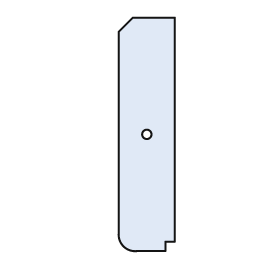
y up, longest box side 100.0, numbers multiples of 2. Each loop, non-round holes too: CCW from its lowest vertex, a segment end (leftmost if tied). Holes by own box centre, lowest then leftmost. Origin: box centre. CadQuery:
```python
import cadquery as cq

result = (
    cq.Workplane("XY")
    .moveTo(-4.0, -50.0)
    .lineTo(8.0, -50.0)
    .lineTo(8.0, -46.0)
    .lineTo(12.0, -46.0)
    .lineTo(12.0, 50.0)
    .lineTo(-6.0, 50.0)
    .lineTo(-12.0, 44.0)
    .lineTo(-12.0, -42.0)
    .threePointArc((-10.0, -48.0), (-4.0, -50.0))
    .close()
    .moveTo(0.0, 0.0)
    .circle(2.0)
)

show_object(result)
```